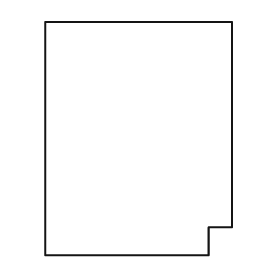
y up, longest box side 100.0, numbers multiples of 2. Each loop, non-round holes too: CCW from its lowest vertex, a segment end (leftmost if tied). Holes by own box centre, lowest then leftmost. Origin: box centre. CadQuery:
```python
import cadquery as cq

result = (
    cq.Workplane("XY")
    .moveTo(-40.0, -50.0)
    .lineTo(30.0, -50.0)
    .lineTo(30.0, -38.0)
    .lineTo(40.0, -38.0)
    .lineTo(40.0, 50.0)
    .lineTo(-40.0, 50.0)
    .close()
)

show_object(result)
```